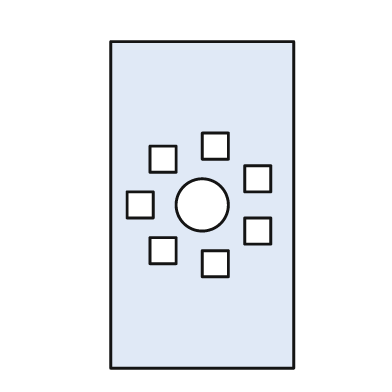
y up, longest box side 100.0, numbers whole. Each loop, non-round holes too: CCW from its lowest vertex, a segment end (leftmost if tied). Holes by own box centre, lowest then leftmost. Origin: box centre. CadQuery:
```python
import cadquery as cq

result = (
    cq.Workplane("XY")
    .moveTo(-28.0, -50.0)
    .lineTo(28.0, -50.0)
    .lineTo(28.0, 50.0)
    .lineTo(-28.0, 50.0)
    .close()
    .moveTo(0.0, -22.0)
    .lineTo(8.0, -22.0)
    .lineTo(8.0, -14.0)
    .lineTo(0.0, -14.0)
    .close()
    .moveTo(-16.0, -18.0)
    .lineTo(-8.0, -18.0)
    .lineTo(-8.0, -10.0)
    .lineTo(-16.0, -10.0)
    .close()
    .moveTo(13.0, -12.0)
    .lineTo(21.0, -12.0)
    .lineTo(21.0, -4.0)
    .lineTo(13.0, -4.0)
    .close()
    .moveTo(-23.0, -4.0)
    .lineTo(-15.0, -4.0)
    .lineTo(-15.0, 4.0)
    .lineTo(-23.0, 4.0)
    .close()
    .moveTo(0.0, 0.0)
    .circle(8.0)
    .moveTo(13.0, 4.0)
    .lineTo(21.0, 4.0)
    .lineTo(21.0, 12.0)
    .lineTo(13.0, 12.0)
    .close()
    .moveTo(-16.0, 10.0)
    .lineTo(-8.0, 10.0)
    .lineTo(-8.0, 18.0)
    .lineTo(-16.0, 18.0)
    .close()
    .moveTo(0.0, 14.0)
    .lineTo(8.0, 14.0)
    .lineTo(8.0, 22.0)
    .lineTo(0.0, 22.0)
    .close()
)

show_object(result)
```